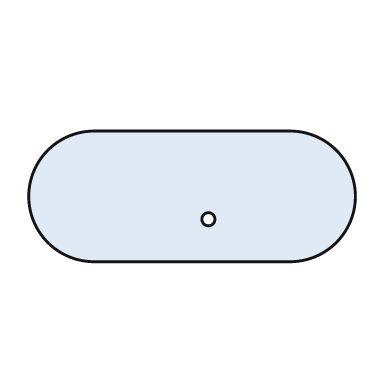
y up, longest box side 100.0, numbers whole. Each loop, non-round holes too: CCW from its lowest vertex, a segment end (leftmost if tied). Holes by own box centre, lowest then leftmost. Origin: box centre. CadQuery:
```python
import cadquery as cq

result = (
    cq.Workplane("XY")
    .moveTo(-30.0, -20.0)
    .lineTo(30.0, -20.0)
    .threePointArc((50.0, 0.0), (30.0, 20.0))
    .lineTo(-30.0, 20.0)
    .threePointArc((-50.0, 0.0), (-30.0, -20.0))
    .close()
    .moveTo(5.0, -7.0)
    .circle(2.0)
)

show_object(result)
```